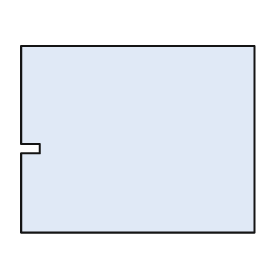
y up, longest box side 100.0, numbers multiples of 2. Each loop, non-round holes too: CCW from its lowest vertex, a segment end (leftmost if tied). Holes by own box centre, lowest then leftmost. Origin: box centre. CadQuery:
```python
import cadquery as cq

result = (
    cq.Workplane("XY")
    .moveTo(-50.0, -40.0)
    .lineTo(50.0, -40.0)
    .lineTo(50.0, 40.0)
    .lineTo(-50.0, 40.0)
    .lineTo(-50.0, -2.0)
    .lineTo(-42.0, -2.0)
    .lineTo(-42.0, -6.0)
    .lineTo(-50.0, -6.0)
    .close()
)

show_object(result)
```